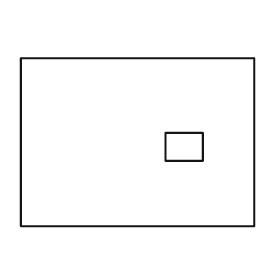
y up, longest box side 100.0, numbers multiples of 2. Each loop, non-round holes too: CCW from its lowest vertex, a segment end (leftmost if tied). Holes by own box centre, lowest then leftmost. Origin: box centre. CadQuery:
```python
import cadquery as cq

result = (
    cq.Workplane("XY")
    .moveTo(-50.0, -36.0)
    .lineTo(50.0, -36.0)
    .lineTo(50.0, 36.0)
    .lineTo(-50.0, 36.0)
    .close()
    .moveTo(12.0, -8.0)
    .lineTo(28.0, -8.0)
    .lineTo(28.0, 4.0)
    .lineTo(12.0, 4.0)
    .close()
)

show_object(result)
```